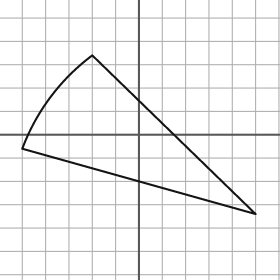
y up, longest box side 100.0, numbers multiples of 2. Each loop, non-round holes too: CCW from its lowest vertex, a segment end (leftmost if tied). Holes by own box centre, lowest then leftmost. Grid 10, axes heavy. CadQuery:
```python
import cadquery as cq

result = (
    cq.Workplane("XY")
    .moveTo(50.0, -34.0)
    .lineTo(-20.0, 34.0)
    .threePointArc((-38.0, 16.0), (-50.0, -6.0))
    .close()
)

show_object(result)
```